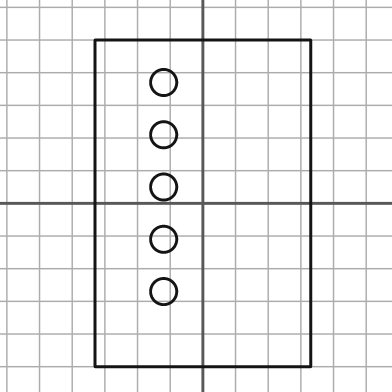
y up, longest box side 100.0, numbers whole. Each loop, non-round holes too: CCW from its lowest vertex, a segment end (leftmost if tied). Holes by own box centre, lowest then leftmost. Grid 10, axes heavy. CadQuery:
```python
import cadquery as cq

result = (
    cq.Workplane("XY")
    .moveTo(-33.0, -50.0)
    .lineTo(33.0, -50.0)
    .lineTo(33.0, 50.0)
    .lineTo(-33.0, 50.0)
    .close()
    .moveTo(-12.0, -27.0)
    .circle(4.0)
    .moveTo(-12.0, -11.0)
    .circle(4.0)
    .moveTo(-12.0, 5.0)
    .circle(4.0)
    .moveTo(-12.0, 21.0)
    .circle(4.0)
    .moveTo(-12.0, 37.0)
    .circle(4.0)
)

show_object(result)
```